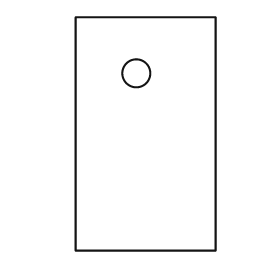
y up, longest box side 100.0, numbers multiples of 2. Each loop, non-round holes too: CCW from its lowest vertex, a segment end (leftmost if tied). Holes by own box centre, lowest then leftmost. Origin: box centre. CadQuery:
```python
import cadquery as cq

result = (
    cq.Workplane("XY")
    .moveTo(-30.0, -50.0)
    .lineTo(30.0, -50.0)
    .lineTo(30.0, 50.0)
    .lineTo(-30.0, 50.0)
    .close()
    .moveTo(-4.0, 26.0)
    .circle(6.0)
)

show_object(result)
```